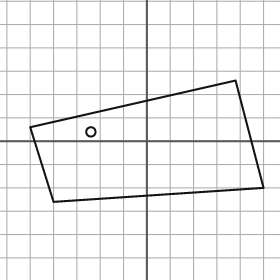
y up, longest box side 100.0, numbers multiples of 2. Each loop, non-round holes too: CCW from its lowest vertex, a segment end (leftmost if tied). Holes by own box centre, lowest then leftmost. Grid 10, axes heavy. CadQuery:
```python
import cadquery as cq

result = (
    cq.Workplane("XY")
    .moveTo(-40.0, -26.0)
    .lineTo(50.0, -20.0)
    .lineTo(38.0, 26.0)
    .lineTo(-50.0, 6.0)
    .close()
    .moveTo(-24.0, 4.0)
    .circle(2.0)
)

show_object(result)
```